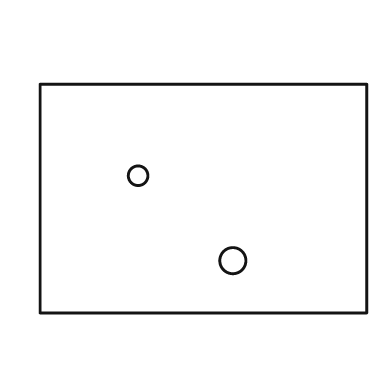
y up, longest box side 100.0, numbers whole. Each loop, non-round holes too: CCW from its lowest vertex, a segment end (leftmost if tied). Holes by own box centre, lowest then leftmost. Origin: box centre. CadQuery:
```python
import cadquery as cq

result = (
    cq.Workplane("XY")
    .moveTo(-50.0, -35.0)
    .lineTo(50.0, -35.0)
    .lineTo(50.0, 35.0)
    .lineTo(-50.0, 35.0)
    .close()
    .moveTo(9.0, -19.0)
    .circle(4.0)
    .moveTo(-20.0, 7.0)
    .circle(3.0)
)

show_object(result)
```